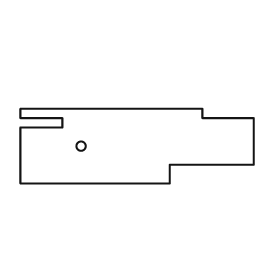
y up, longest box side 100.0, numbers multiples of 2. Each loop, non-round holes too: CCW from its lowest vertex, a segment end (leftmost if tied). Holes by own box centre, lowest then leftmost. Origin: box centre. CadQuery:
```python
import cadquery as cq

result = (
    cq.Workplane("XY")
    .moveTo(-50.0, -16.0)
    .lineTo(14.0, -16.0)
    .lineTo(14.0, -8.0)
    .lineTo(50.0, -8.0)
    .lineTo(50.0, 12.0)
    .lineTo(28.0, 12.0)
    .lineTo(28.0, 16.0)
    .lineTo(-50.0, 16.0)
    .lineTo(-50.0, 12.0)
    .lineTo(-32.0, 12.0)
    .lineTo(-32.0, 8.0)
    .lineTo(-50.0, 8.0)
    .close()
    .moveTo(-24.0, 0.0)
    .circle(2.0)
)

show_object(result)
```